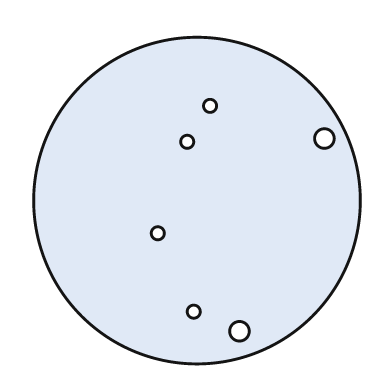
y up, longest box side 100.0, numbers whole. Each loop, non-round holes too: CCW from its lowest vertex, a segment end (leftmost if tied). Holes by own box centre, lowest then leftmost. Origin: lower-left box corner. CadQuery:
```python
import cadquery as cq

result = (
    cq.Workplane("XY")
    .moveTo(50.0, 50.0)
    .circle(50.0)
    .moveTo(63.0, 10.0)
    .circle(3.0)
    .moveTo(49.0, 16.0)
    .circle(2.0)
    .moveTo(38.0, 40.0)
    .circle(2.0)
    .moveTo(47.0, 68.0)
    .circle(2.0)
    .moveTo(89.0, 69.0)
    .circle(3.0)
    .moveTo(54.0, 79.0)
    .circle(2.0)
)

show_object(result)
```